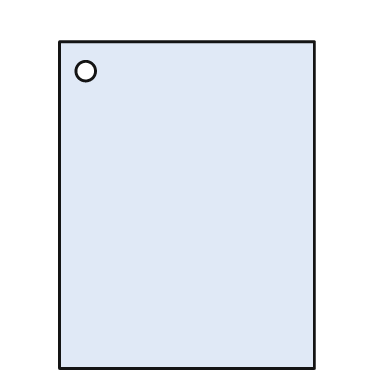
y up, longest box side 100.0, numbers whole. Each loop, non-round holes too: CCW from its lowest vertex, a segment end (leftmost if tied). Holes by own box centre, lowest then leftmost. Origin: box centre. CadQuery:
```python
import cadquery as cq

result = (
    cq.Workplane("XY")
    .moveTo(-39.0, -50.0)
    .lineTo(39.0, -50.0)
    .lineTo(39.0, 50.0)
    .lineTo(-39.0, 50.0)
    .close()
    .moveTo(-31.0, 41.0)
    .circle(3.0)
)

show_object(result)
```